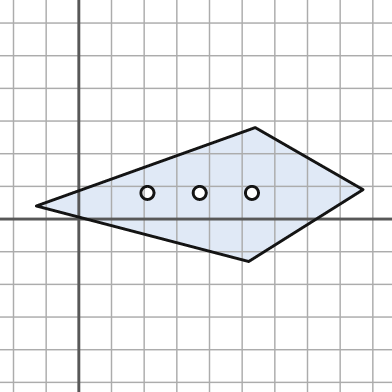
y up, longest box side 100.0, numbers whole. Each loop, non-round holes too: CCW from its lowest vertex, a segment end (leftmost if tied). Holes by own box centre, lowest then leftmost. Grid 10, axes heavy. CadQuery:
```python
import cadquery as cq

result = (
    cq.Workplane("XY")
    .moveTo(52.0, -13.0)
    .lineTo(87.0, 9.0)
    .lineTo(54.0, 28.0)
    .lineTo(-13.0, 4.0)
    .close()
    .moveTo(21.0, 8.0)
    .circle(2.0)
    .moveTo(37.0, 8.0)
    .circle(2.0)
    .moveTo(53.0, 8.0)
    .circle(2.0)
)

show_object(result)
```